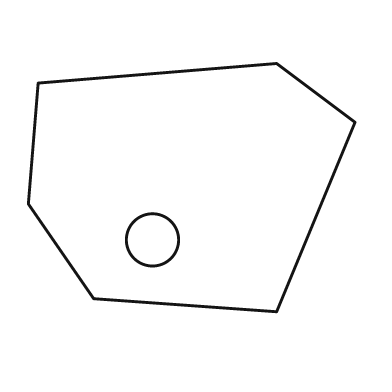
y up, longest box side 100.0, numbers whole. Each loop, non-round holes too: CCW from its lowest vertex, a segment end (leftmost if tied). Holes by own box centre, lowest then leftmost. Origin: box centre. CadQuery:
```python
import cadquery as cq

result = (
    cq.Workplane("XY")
    .moveTo(26.0, -38.0)
    .lineTo(50.0, 20.0)
    .lineTo(26.0, 38.0)
    .lineTo(-47.0, 32.0)
    .lineTo(-50.0, -5.0)
    .lineTo(-30.0, -34.0)
    .close()
    .moveTo(-12.0, -16.0)
    .circle(8.0)
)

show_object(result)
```